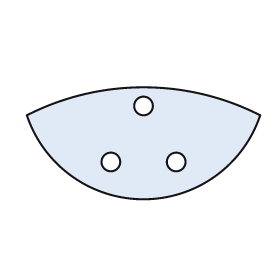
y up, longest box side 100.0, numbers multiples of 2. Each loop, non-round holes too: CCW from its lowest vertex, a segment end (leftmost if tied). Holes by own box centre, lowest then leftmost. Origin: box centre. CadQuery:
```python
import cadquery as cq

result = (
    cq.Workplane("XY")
    .moveTo(-50.0, 12.0)
    .threePointArc((0.0, -24.0), (50.0, 12.0))
    .threePointArc((0.0, 24.0), (-50.0, 12.0))
    .close()
    .moveTo(-14.0, -8.0)
    .circle(4.0)
    .moveTo(14.0, -8.0)
    .circle(4.0)
    .moveTo(0.0, 16.0)
    .circle(4.0)
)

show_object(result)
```